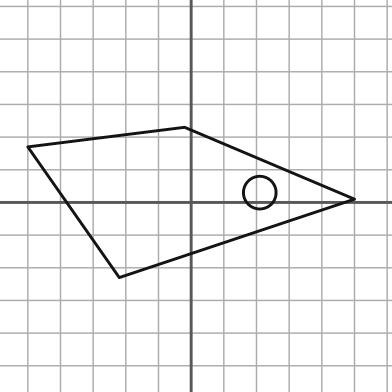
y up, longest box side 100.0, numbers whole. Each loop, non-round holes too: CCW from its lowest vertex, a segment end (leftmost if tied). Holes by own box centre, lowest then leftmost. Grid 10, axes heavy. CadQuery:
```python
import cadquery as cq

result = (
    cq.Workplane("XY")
    .moveTo(-22.0, -23.0)
    .lineTo(50.0, 1.0)
    .lineTo(-2.0, 23.0)
    .lineTo(-50.0, 17.0)
    .close()
    .moveTo(21.0, 3.0)
    .circle(5.0)
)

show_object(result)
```